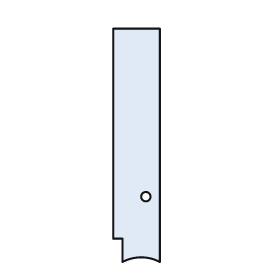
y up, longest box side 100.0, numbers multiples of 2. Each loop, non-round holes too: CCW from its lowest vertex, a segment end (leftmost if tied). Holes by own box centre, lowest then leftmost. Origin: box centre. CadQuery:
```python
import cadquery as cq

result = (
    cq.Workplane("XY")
    .moveTo(-6.0, -50.0)
    .threePointArc((2.0, -48.0), (10.0, -50.0))
    .lineTo(10.0, 50.0)
    .lineTo(-10.0, 50.0)
    .lineTo(-10.0, -40.0)
    .lineTo(-6.0, -40.0)
    .close()
    .moveTo(4.0, -22.0)
    .circle(2.0)
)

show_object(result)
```